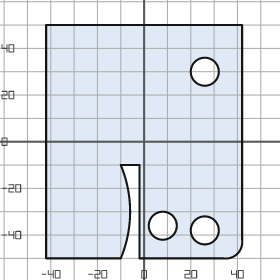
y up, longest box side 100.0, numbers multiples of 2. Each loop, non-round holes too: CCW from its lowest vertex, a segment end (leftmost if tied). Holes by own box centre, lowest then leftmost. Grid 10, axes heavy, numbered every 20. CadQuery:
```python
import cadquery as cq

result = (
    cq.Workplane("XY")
    .moveTo(-42.0, -50.0)
    .lineTo(-10.0, -50.0)
    .threePointArc((-6.0, -30.0), (-10.0, -10.0))
    .lineTo(-2.0, -10.0)
    .lineTo(-2.0, -50.0)
    .lineTo(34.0, -50.0)
    .threePointArc((40.0, -48.0), (42.0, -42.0))
    .lineTo(42.0, 50.0)
    .lineTo(-42.0, 50.0)
    .close()
    .moveTo(26.0, -38.0)
    .circle(6.0)
    .moveTo(8.0, -36.0)
    .circle(6.0)
    .moveTo(26.0, 30.0)
    .circle(6.0)
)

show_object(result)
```